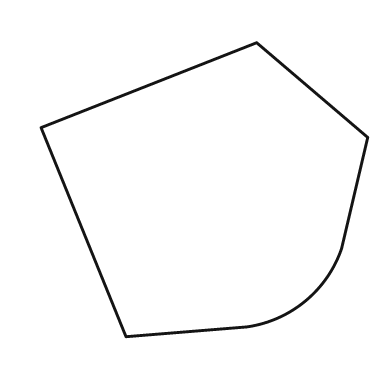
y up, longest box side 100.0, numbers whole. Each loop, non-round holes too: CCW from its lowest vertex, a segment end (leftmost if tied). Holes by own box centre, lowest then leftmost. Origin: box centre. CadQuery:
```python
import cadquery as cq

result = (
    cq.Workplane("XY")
    .moveTo(-24.0, -45.0)
    .lineTo(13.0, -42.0)
    .threePointArc((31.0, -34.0), (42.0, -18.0))
    .lineTo(50.0, 16.0)
    .lineTo(16.0, 45.0)
    .lineTo(-50.0, 19.0)
    .close()
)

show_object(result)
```